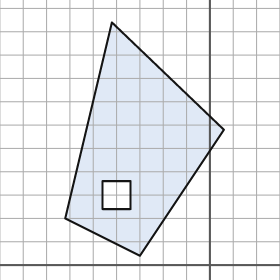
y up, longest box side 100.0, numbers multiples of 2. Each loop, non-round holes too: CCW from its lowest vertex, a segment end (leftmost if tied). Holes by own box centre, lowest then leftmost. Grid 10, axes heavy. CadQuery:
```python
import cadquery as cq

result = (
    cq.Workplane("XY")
    .moveTo(-30.0, 4.0)
    .lineTo(6.0, 58.0)
    .lineTo(-42.0, 104.0)
    .lineTo(-62.0, 20.0)
    .close()
    .moveTo(-46.0, 24.0)
    .lineTo(-34.0, 24.0)
    .lineTo(-34.0, 36.0)
    .lineTo(-46.0, 36.0)
    .close()
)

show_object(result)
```